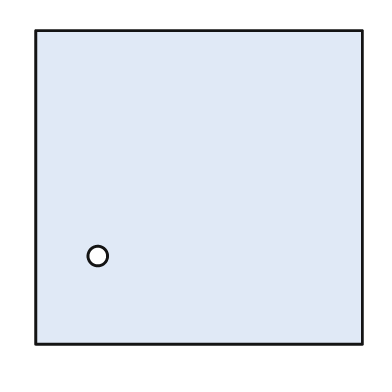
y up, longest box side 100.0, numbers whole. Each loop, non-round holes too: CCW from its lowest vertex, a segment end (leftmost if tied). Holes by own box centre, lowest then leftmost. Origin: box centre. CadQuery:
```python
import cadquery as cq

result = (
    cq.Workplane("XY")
    .moveTo(-50.0, -48.0)
    .lineTo(50.0, -48.0)
    .lineTo(50.0, 48.0)
    .lineTo(-50.0, 48.0)
    .close()
    .moveTo(-31.0, -21.0)
    .circle(3.0)
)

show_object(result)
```